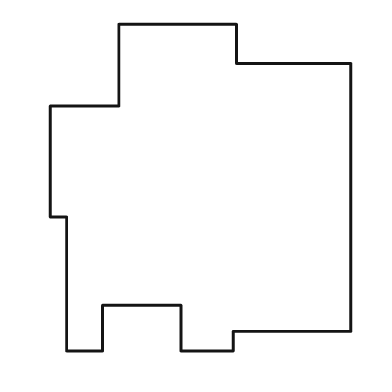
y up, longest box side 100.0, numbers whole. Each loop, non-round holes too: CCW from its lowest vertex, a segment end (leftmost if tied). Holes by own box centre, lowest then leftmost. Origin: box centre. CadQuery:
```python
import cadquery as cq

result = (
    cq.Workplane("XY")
    .moveTo(-41.0, -50.0)
    .lineTo(-30.0, -50.0)
    .lineTo(-30.0, -36.0)
    .lineTo(-6.0, -36.0)
    .lineTo(-6.0, -50.0)
    .lineTo(10.0, -50.0)
    .lineTo(10.0, -44.0)
    .lineTo(46.0, -44.0)
    .lineTo(46.0, 38.0)
    .lineTo(11.0, 38.0)
    .lineTo(11.0, 50.0)
    .lineTo(-25.0, 50.0)
    .lineTo(-25.0, 25.0)
    .lineTo(-46.0, 25.0)
    .lineTo(-46.0, -9.0)
    .lineTo(-41.0, -9.0)
    .close()
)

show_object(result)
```